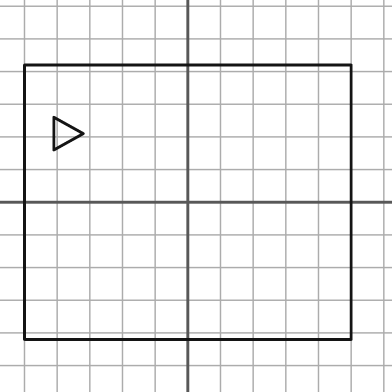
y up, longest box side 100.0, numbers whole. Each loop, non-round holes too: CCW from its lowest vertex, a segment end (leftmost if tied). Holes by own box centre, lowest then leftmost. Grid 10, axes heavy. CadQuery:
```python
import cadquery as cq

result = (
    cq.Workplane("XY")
    .moveTo(-50.0, -42.0)
    .lineTo(50.0, -42.0)
    .lineTo(50.0, 42.0)
    .lineTo(-50.0, 42.0)
    .close()
    .moveTo(-41.0, 16.0)
    .lineTo(-32.0, 21.0)
    .lineTo(-41.0, 26.0)
    .close()
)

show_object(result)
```